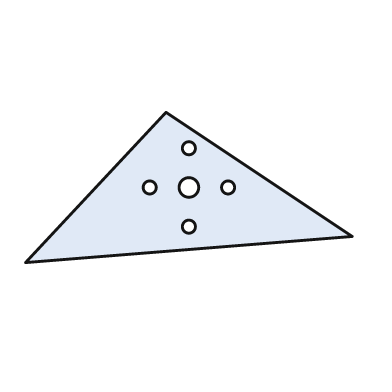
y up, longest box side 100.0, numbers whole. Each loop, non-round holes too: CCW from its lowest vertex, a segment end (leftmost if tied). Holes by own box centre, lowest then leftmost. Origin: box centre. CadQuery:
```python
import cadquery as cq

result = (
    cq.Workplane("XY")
    .moveTo(-50.0, -23.0)
    .lineTo(50.0, -15.0)
    .lineTo(-7.0, 23.0)
    .close()
    .moveTo(0.0, -12.0)
    .circle(2.0)
    .moveTo(-12.0, 0.0)
    .circle(2.0)
    .moveTo(0.0, 0.0)
    .circle(3.0)
    .moveTo(12.0, 0.0)
    .circle(2.0)
    .moveTo(0.0, 12.0)
    .circle(2.0)
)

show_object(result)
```